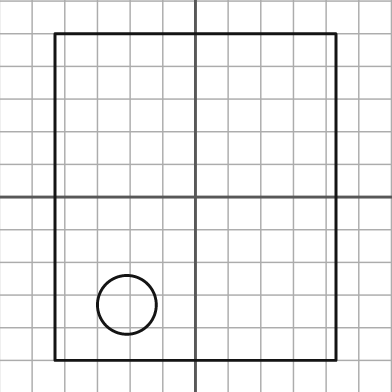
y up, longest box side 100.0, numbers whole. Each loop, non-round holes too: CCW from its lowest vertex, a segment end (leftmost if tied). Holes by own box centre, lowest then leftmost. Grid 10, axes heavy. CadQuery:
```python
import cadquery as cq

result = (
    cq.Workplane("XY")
    .moveTo(-43.0, -50.0)
    .lineTo(43.0, -50.0)
    .lineTo(43.0, 50.0)
    .lineTo(-43.0, 50.0)
    .close()
    .moveTo(-21.0, -33.0)
    .circle(9.0)
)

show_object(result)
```